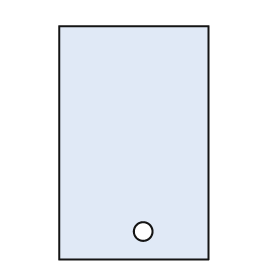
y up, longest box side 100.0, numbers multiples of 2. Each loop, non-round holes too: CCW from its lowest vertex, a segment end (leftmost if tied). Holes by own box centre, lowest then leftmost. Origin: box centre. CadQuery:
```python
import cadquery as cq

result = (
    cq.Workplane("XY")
    .moveTo(-32.0, -50.0)
    .lineTo(32.0, -50.0)
    .lineTo(32.0, 50.0)
    .lineTo(-32.0, 50.0)
    .close()
    .moveTo(4.0, -38.0)
    .circle(4.0)
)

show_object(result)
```